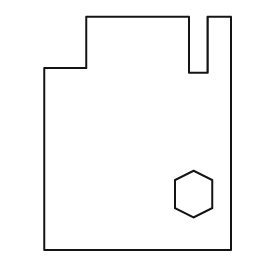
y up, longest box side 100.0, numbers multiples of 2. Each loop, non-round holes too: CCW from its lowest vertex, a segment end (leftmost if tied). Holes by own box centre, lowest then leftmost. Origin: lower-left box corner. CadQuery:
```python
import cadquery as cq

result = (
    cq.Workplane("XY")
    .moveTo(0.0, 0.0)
    .lineTo(80.0, 0.0)
    .lineTo(80.0, 100.0)
    .lineTo(70.0, 100.0)
    .lineTo(70.0, 76.0)
    .lineTo(62.0, 76.0)
    .lineTo(62.0, 100.0)
    .lineTo(18.0, 100.0)
    .lineTo(18.0, 78.0)
    .lineTo(0.0, 78.0)
    .close()
    .moveTo(64.0, 14.0)
    .lineTo(72.0, 18.0)
    .lineTo(72.0, 30.0)
    .lineTo(64.0, 34.0)
    .lineTo(56.0, 30.0)
    .lineTo(56.0, 18.0)
    .close()
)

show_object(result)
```